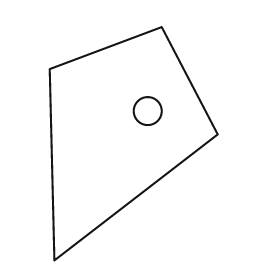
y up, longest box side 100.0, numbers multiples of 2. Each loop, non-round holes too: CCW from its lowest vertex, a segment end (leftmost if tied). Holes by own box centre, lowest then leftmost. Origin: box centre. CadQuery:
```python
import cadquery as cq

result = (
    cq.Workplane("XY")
    .moveTo(-34.0, -50.0)
    .lineTo(36.0, 4.0)
    .lineTo(12.0, 50.0)
    .lineTo(-36.0, 32.0)
    .close()
    .moveTo(6.0, 14.0)
    .circle(6.0)
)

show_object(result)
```